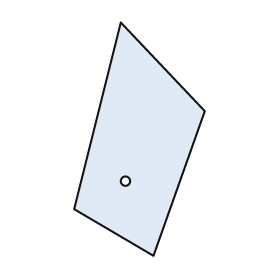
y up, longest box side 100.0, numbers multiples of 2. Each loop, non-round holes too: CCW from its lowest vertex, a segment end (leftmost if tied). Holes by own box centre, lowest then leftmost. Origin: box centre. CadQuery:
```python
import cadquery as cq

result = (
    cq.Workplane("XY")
    .moveTo(6.0, -50.0)
    .lineTo(28.0, 12.0)
    .lineTo(-8.0, 50.0)
    .lineTo(-28.0, -30.0)
    .close()
    .moveTo(-6.0, -18.0)
    .circle(2.0)
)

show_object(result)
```